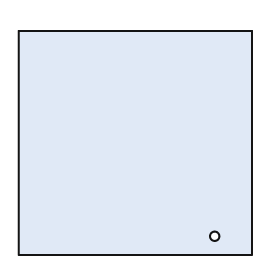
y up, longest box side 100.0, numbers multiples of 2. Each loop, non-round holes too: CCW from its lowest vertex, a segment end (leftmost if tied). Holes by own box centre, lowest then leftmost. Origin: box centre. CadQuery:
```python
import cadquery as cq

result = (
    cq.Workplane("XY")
    .moveTo(-50.0, -48.0)
    .lineTo(50.0, -48.0)
    .lineTo(50.0, 48.0)
    .lineTo(-50.0, 48.0)
    .close()
    .moveTo(34.0, -40.0)
    .circle(2.0)
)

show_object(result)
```